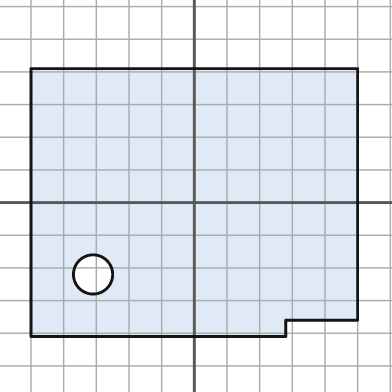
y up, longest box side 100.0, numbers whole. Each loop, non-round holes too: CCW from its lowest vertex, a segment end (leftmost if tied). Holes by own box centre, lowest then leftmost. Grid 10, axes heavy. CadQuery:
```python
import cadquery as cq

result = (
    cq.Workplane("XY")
    .moveTo(-50.0, -41.0)
    .lineTo(28.0, -41.0)
    .lineTo(28.0, -36.0)
    .lineTo(50.0, -36.0)
    .lineTo(50.0, 41.0)
    .lineTo(-50.0, 41.0)
    .close()
    .moveTo(-31.0, -22.0)
    .circle(6.0)
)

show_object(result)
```